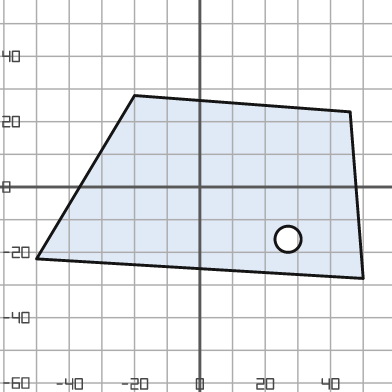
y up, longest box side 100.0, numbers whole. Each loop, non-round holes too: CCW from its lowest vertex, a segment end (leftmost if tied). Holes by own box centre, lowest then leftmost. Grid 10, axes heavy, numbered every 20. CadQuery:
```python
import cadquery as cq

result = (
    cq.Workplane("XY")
    .moveTo(50.0, -28.0)
    .lineTo(46.0, 23.0)
    .lineTo(-20.0, 28.0)
    .lineTo(-50.0, -22.0)
    .close()
    .moveTo(27.0, -16.0)
    .circle(4.0)
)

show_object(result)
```